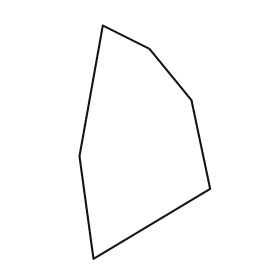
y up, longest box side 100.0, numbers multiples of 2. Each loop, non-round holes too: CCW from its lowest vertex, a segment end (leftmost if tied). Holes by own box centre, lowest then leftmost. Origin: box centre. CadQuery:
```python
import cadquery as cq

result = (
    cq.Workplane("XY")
    .moveTo(-22.0, -50.0)
    .lineTo(28.0, -20.0)
    .lineTo(20.0, 18.0)
    .lineTo(2.0, 40.0)
    .lineTo(-18.0, 50.0)
    .lineTo(-28.0, -6.0)
    .close()
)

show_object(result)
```